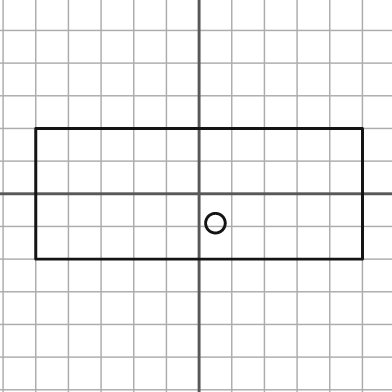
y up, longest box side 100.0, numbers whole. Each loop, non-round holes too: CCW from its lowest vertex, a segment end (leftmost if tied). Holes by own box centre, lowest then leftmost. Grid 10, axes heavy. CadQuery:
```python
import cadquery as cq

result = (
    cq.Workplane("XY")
    .moveTo(-50.0, -20.0)
    .lineTo(50.0, -20.0)
    .lineTo(50.0, 20.0)
    .lineTo(-50.0, 20.0)
    .close()
    .moveTo(5.0, -9.0)
    .circle(3.0)
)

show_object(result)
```